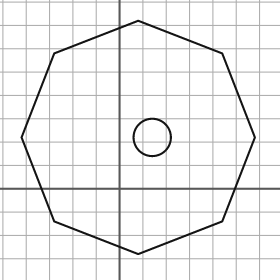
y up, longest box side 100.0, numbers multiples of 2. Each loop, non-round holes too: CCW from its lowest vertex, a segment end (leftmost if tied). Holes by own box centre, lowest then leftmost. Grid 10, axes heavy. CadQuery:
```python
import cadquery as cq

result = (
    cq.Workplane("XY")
    .moveTo(8.0, -28.0)
    .lineTo(44.0, -14.0)
    .lineTo(58.0, 22.0)
    .lineTo(44.0, 58.0)
    .lineTo(8.0, 72.0)
    .lineTo(-28.0, 58.0)
    .lineTo(-42.0, 22.0)
    .lineTo(-28.0, -14.0)
    .close()
    .moveTo(14.0, 22.0)
    .circle(8.0)
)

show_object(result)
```